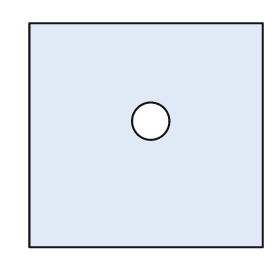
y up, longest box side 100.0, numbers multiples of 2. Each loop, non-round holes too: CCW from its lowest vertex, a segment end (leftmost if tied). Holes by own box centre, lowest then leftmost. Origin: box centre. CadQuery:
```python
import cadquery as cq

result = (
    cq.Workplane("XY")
    .moveTo(-50.0, -48.0)
    .lineTo(50.0, -48.0)
    .lineTo(50.0, 48.0)
    .lineTo(-50.0, 48.0)
    .close()
    .moveTo(2.0, 6.0)
    .circle(8.0)
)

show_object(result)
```